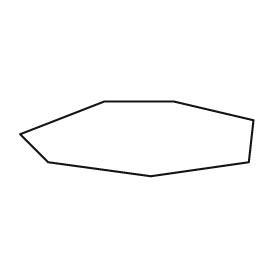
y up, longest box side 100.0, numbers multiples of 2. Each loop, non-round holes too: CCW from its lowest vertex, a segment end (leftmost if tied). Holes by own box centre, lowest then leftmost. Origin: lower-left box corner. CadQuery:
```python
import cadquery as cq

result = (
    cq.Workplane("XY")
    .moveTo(56.0, 0.0)
    .lineTo(98.0, 6.0)
    .lineTo(100.0, 24.0)
    .lineTo(66.0, 32.0)
    .lineTo(36.0, 32.0)
    .lineTo(0.0, 18.0)
    .lineTo(12.0, 6.0)
    .close()
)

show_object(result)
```